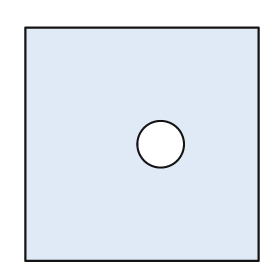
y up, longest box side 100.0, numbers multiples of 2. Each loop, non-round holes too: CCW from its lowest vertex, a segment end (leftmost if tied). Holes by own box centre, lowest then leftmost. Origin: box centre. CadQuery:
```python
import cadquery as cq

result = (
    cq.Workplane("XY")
    .moveTo(-50.0, -50.0)
    .lineTo(50.0, -50.0)
    .lineTo(50.0, 50.0)
    .lineTo(-50.0, 50.0)
    .close()
    .moveTo(8.0, 0.0)
    .circle(10.0)
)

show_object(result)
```